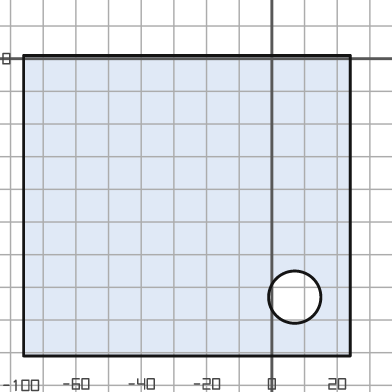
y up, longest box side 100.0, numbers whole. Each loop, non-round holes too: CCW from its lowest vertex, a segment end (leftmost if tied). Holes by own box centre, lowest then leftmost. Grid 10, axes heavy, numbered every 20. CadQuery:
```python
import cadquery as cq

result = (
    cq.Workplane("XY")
    .moveTo(-76.0, -91.0)
    .lineTo(24.0, -91.0)
    .lineTo(24.0, 1.0)
    .lineTo(-76.0, 1.0)
    .close()
    .moveTo(7.0, -73.0)
    .circle(8.0)
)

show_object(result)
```